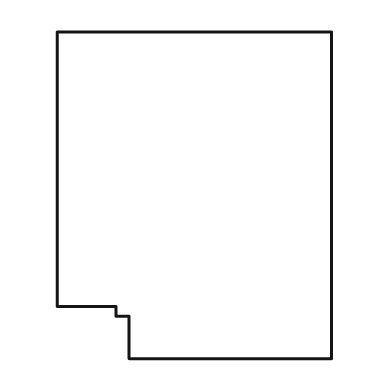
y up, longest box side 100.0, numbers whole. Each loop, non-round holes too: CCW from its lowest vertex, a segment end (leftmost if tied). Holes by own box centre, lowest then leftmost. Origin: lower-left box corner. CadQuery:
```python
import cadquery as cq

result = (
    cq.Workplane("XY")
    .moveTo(22.0, 0.0)
    .lineTo(84.0, 0.0)
    .lineTo(84.0, 100.0)
    .lineTo(0.0, 100.0)
    .lineTo(0.0, 16.0)
    .lineTo(18.0, 16.0)
    .lineTo(18.0, 13.0)
    .lineTo(22.0, 13.0)
    .close()
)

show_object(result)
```